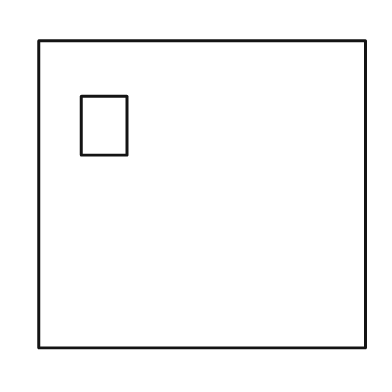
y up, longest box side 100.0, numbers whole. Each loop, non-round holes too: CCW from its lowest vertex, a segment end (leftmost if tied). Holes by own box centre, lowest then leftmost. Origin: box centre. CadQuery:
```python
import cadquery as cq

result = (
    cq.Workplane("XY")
    .moveTo(-50.0, -47.0)
    .lineTo(50.0, -47.0)
    .lineTo(50.0, 47.0)
    .lineTo(-50.0, 47.0)
    .close()
    .moveTo(-37.0, 12.0)
    .lineTo(-23.0, 12.0)
    .lineTo(-23.0, 30.0)
    .lineTo(-37.0, 30.0)
    .close()
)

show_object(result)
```